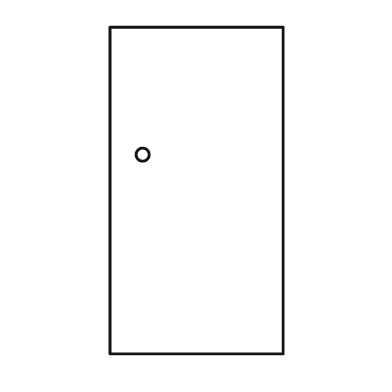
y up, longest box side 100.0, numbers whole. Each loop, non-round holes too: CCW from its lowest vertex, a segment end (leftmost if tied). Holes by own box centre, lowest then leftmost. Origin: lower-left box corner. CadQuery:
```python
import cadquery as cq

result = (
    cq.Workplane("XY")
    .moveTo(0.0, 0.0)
    .lineTo(53.0, 0.0)
    .lineTo(53.0, 100.0)
    .lineTo(0.0, 100.0)
    .close()
    .moveTo(10.0, 61.0)
    .circle(2.0)
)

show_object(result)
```